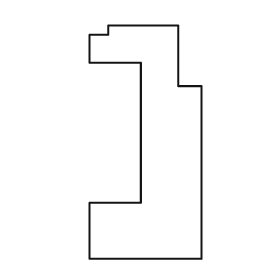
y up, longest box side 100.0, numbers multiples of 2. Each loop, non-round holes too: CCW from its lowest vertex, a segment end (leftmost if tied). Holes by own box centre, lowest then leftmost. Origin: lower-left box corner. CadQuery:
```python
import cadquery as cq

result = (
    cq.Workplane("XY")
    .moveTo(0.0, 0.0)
    .lineTo(48.0, 0.0)
    .lineTo(48.0, 74.0)
    .lineTo(38.0, 74.0)
    .lineTo(38.0, 100.0)
    .lineTo(8.0, 100.0)
    .lineTo(8.0, 96.0)
    .lineTo(0.0, 96.0)
    .lineTo(0.0, 84.0)
    .lineTo(22.0, 84.0)
    .lineTo(22.0, 24.0)
    .lineTo(0.0, 24.0)
    .close()
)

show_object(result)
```